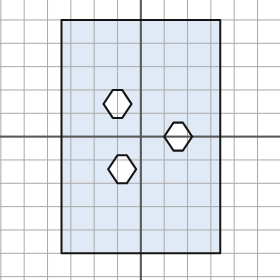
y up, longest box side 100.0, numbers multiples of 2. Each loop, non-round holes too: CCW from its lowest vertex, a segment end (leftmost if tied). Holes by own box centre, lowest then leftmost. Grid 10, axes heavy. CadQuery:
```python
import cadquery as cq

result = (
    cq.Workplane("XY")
    .moveTo(-34.0, -50.0)
    .lineTo(34.0, -50.0)
    .lineTo(34.0, 50.0)
    .lineTo(-34.0, 50.0)
    .close()
    .moveTo(-10.0, -20.0)
    .lineTo(-6.0, -20.0)
    .lineTo(-2.0, -14.0)
    .lineTo(-6.0, -8.0)
    .lineTo(-10.0, -8.0)
    .lineTo(-14.0, -14.0)
    .close()
    .moveTo(14.0, -6.0)
    .lineTo(18.0, -6.0)
    .lineTo(22.0, 0.0)
    .lineTo(18.0, 6.0)
    .lineTo(14.0, 6.0)
    .lineTo(10.0, 0.0)
    .close()
    .moveTo(-12.0, 8.0)
    .lineTo(-8.0, 8.0)
    .lineTo(-4.0, 14.0)
    .lineTo(-8.0, 20.0)
    .lineTo(-12.0, 20.0)
    .lineTo(-16.0, 14.0)
    .close()
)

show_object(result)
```